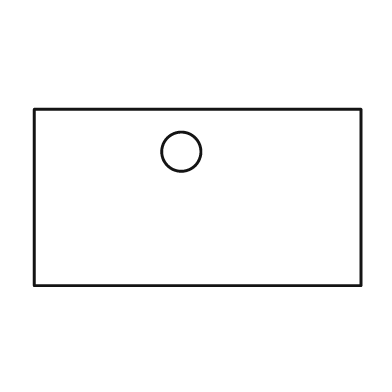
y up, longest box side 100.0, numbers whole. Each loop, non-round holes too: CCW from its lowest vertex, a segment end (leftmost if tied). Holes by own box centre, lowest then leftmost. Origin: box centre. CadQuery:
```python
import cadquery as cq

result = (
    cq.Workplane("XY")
    .moveTo(-50.0, -27.0)
    .lineTo(50.0, -27.0)
    .lineTo(50.0, 27.0)
    .lineTo(-50.0, 27.0)
    .close()
    .moveTo(-5.0, 14.0)
    .circle(6.0)
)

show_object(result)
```